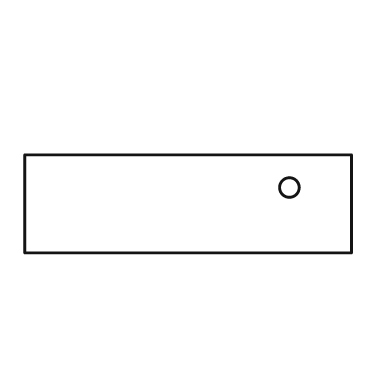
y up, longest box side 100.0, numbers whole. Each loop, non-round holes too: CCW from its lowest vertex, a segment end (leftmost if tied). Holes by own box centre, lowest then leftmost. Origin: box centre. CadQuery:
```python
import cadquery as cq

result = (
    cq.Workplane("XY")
    .moveTo(-50.0, -15.0)
    .lineTo(50.0, -15.0)
    .lineTo(50.0, 15.0)
    .lineTo(-50.0, 15.0)
    .close()
    .moveTo(31.0, 5.0)
    .circle(3.0)
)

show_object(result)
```